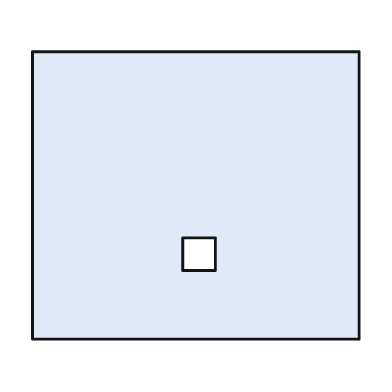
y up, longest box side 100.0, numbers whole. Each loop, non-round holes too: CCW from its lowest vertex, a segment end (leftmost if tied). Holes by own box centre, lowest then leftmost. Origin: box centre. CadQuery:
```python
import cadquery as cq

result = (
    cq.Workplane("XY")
    .moveTo(-50.0, -44.0)
    .lineTo(50.0, -44.0)
    .lineTo(50.0, 44.0)
    .lineTo(-50.0, 44.0)
    .close()
    .moveTo(-4.0, -23.0)
    .lineTo(6.0, -23.0)
    .lineTo(6.0, -13.0)
    .lineTo(-4.0, -13.0)
    .close()
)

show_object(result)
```